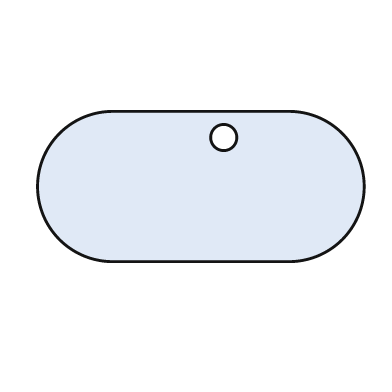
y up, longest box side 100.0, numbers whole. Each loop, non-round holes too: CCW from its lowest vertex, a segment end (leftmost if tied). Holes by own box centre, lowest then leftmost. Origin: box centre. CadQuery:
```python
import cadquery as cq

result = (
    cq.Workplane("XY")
    .moveTo(-27.0, -23.0)
    .lineTo(27.0, -23.0)
    .threePointArc((50.0, 0.0), (27.0, 23.0))
    .lineTo(-27.0, 23.0)
    .threePointArc((-50.0, 0.0), (-27.0, -23.0))
    .close()
    .moveTo(7.0, 15.0)
    .circle(4.0)
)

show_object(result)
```